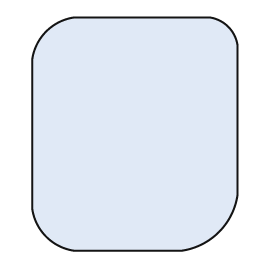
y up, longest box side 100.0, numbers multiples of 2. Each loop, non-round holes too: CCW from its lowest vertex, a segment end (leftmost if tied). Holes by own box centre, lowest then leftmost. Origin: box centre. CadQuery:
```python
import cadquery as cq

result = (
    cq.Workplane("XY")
    .moveTo(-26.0, -50.0)
    .lineTo(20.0, -50.0)
    .threePointArc((36.0, -42.0), (44.0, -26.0))
    .lineTo(44.0, 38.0)
    .threePointArc((40.0, 46.0), (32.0, 50.0))
    .lineTo(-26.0, 50.0)
    .threePointArc((-38.0, 44.0), (-44.0, 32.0))
    .lineTo(-44.0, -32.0)
    .threePointArc((-38.0, -44.0), (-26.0, -50.0))
    .close()
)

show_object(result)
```